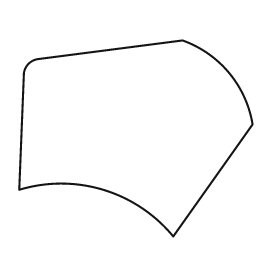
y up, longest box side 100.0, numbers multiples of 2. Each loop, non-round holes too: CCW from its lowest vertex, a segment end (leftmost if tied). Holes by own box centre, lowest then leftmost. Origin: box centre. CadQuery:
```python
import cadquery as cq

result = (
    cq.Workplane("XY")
    .moveTo(16.0, -42.0)
    .lineTo(50.0, 6.0)
    .threePointArc((40.0, 28.0), (20.0, 42.0))
    .lineTo(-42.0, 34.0)
    .threePointArc((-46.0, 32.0), (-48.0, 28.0))
    .lineTo(-50.0, -22.0)
    .threePointArc((-14.0, -22.0), (16.0, -42.0))
    .close()
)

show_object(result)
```